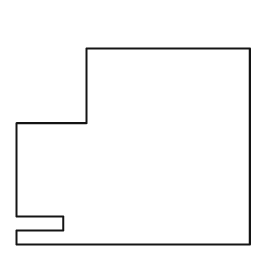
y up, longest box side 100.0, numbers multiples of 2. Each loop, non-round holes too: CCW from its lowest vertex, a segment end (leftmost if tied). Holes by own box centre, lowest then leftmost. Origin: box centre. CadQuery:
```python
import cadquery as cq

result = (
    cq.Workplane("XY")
    .moveTo(-50.0, -42.0)
    .lineTo(50.0, -42.0)
    .lineTo(50.0, 42.0)
    .lineTo(-20.0, 42.0)
    .lineTo(-20.0, 10.0)
    .lineTo(-50.0, 10.0)
    .lineTo(-50.0, -30.0)
    .lineTo(-30.0, -30.0)
    .lineTo(-30.0, -36.0)
    .lineTo(-50.0, -36.0)
    .close()
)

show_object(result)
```